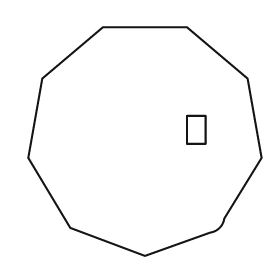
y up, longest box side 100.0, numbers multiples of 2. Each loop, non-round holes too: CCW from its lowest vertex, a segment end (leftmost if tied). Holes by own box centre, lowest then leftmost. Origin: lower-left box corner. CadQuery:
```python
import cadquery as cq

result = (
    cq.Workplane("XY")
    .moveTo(50.0, 0.0)
    .lineTo(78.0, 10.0)
    .threePointArc((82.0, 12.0), (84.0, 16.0))
    .lineTo(100.0, 42.0)
    .lineTo(94.0, 76.0)
    .lineTo(68.0, 98.0)
    .lineTo(32.0, 98.0)
    .lineTo(6.0, 76.0)
    .lineTo(0.0, 42.0)
    .lineTo(18.0, 12.0)
    .close()
    .moveTo(68.0, 48.0)
    .lineTo(76.0, 48.0)
    .lineTo(76.0, 60.0)
    .lineTo(68.0, 60.0)
    .close()
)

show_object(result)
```